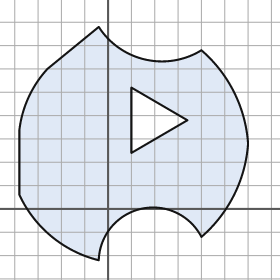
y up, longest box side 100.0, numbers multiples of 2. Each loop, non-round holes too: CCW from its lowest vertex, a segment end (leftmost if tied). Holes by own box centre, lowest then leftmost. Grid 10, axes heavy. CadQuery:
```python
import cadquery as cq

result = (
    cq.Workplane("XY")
    .moveTo(-4.0, -22.0)
    .threePointArc((14.0, 0.0), (40.0, -12.0))
    .threePointArc((54.0, 6.0), (60.0, 28.0))
    .threePointArc((54.0, 50.0), (40.0, 68.0))
    .threePointArc((16.0, 64.0), (-4.0, 78.0))
    .lineTo(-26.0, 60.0)
    .threePointArc((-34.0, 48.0), (-38.0, 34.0))
    .lineTo(-38.0, 6.0)
    .threePointArc((-24.0, -12.0), (-4.0, -22.0))
    .close()
    .moveTo(10.0, 24.0)
    .lineTo(34.0, 38.0)
    .lineTo(10.0, 52.0)
    .close()
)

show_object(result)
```